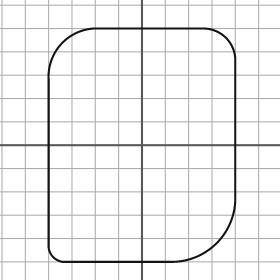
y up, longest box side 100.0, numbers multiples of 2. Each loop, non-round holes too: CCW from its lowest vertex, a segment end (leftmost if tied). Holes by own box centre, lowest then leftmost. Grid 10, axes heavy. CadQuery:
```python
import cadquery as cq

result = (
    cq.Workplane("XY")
    .moveTo(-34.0, -50.0)
    .lineTo(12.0, -50.0)
    .threePointArc((32.0, -42.0), (40.0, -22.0))
    .lineTo(40.0, 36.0)
    .threePointArc((36.0, 46.0), (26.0, 50.0))
    .lineTo(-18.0, 50.0)
    .threePointArc((-34.0, 44.0), (-40.0, 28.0))
    .lineTo(-40.0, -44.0)
    .threePointArc((-38.0, -48.0), (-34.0, -50.0))
    .close()
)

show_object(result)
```